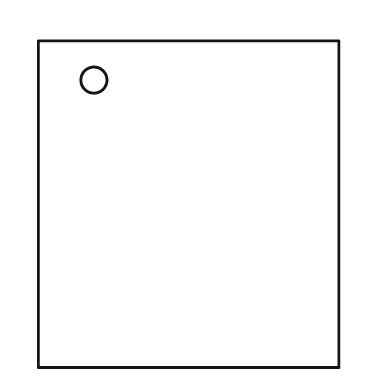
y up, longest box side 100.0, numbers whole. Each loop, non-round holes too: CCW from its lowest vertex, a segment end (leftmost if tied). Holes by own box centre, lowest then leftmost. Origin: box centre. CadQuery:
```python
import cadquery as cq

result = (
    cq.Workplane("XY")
    .moveTo(-46.0, -50.0)
    .lineTo(46.0, -50.0)
    .lineTo(46.0, 50.0)
    .lineTo(-46.0, 50.0)
    .close()
    .moveTo(-29.0, 38.0)
    .circle(4.0)
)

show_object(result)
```